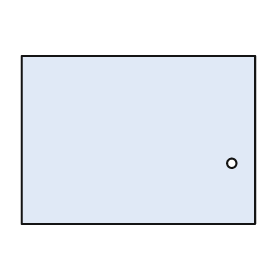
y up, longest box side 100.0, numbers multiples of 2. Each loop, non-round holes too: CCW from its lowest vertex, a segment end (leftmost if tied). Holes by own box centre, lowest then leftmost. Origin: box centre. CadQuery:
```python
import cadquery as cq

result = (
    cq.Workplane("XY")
    .moveTo(-50.0, -36.0)
    .lineTo(50.0, -36.0)
    .lineTo(50.0, 36.0)
    .lineTo(-50.0, 36.0)
    .close()
    .moveTo(40.0, -10.0)
    .circle(2.0)
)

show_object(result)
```